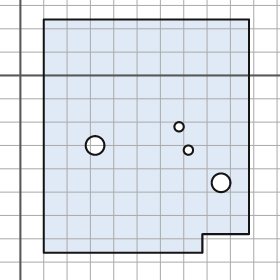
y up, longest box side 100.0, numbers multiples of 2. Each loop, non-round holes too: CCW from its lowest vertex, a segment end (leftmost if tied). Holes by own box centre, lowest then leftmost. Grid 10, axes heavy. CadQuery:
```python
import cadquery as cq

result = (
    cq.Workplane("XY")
    .moveTo(10.0, -76.0)
    .lineTo(78.0, -76.0)
    .lineTo(78.0, -68.0)
    .lineTo(98.0, -68.0)
    .lineTo(98.0, 24.0)
    .lineTo(10.0, 24.0)
    .close()
    .moveTo(86.0, -46.0)
    .circle(4.0)
    .moveTo(72.0, -32.0)
    .circle(2.0)
    .moveTo(32.0, -30.0)
    .circle(4.0)
    .moveTo(68.0, -22.0)
    .circle(2.0)
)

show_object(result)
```